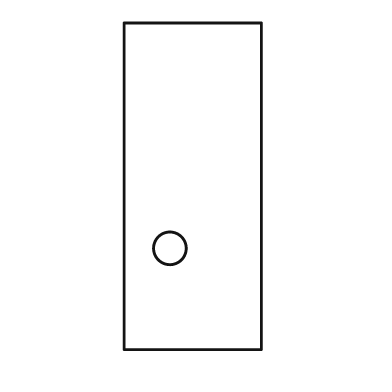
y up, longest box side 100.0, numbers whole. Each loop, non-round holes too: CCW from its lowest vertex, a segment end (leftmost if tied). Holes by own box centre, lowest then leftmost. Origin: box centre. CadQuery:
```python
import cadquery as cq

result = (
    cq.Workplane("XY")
    .moveTo(-21.0, -50.0)
    .lineTo(21.0, -50.0)
    .lineTo(21.0, 50.0)
    .lineTo(-21.0, 50.0)
    .close()
    .moveTo(-7.0, -19.0)
    .circle(5.0)
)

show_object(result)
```